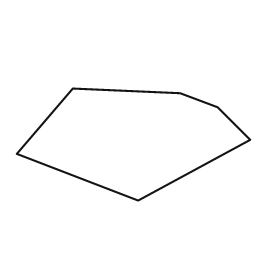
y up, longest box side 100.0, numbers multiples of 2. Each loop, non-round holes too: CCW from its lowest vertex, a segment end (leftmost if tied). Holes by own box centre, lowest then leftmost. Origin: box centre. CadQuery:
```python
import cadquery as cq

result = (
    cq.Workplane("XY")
    .moveTo(2.0, -24.0)
    .lineTo(50.0, 2.0)
    .lineTo(36.0, 16.0)
    .lineTo(20.0, 22.0)
    .lineTo(-26.0, 24.0)
    .lineTo(-50.0, -4.0)
    .close()
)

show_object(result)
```